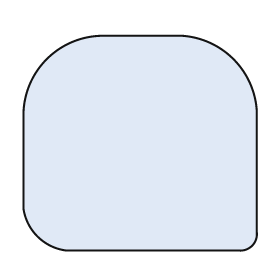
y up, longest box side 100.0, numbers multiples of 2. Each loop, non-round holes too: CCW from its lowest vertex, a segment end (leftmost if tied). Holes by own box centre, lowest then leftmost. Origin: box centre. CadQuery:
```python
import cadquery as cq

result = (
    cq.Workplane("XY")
    .moveTo(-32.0, -46.0)
    .lineTo(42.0, -46.0)
    .threePointArc((48.0, -44.0), (50.0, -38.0))
    .lineTo(50.0, 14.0)
    .threePointArc((40.0, 36.0), (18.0, 46.0))
    .lineTo(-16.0, 46.0)
    .threePointArc((-40.0, 36.0), (-50.0, 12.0))
    .lineTo(-50.0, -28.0)
    .threePointArc((-44.0, -40.0), (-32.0, -46.0))
    .close()
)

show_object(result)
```